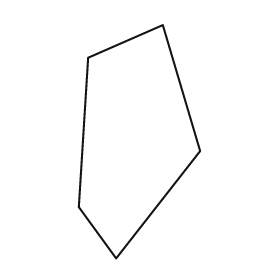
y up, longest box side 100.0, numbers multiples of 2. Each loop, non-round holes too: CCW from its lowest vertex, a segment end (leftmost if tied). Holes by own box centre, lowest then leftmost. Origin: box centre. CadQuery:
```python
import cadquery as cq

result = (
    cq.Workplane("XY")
    .moveTo(-10.0, -50.0)
    .lineTo(26.0, -4.0)
    .lineTo(10.0, 50.0)
    .lineTo(-22.0, 36.0)
    .lineTo(-26.0, -28.0)
    .close()
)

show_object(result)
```